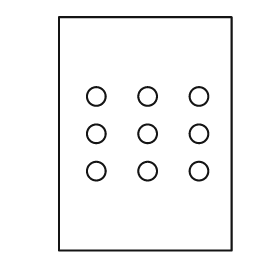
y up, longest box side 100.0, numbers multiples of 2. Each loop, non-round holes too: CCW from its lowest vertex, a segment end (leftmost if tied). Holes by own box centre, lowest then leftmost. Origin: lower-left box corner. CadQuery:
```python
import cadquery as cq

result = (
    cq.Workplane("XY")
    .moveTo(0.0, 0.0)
    .lineTo(74.0, 0.0)
    .lineTo(74.0, 100.0)
    .lineTo(0.0, 100.0)
    .close()
    .moveTo(16.0, 34.0)
    .circle(4.0)
    .moveTo(38.0, 34.0)
    .circle(4.0)
    .moveTo(60.0, 34.0)
    .circle(4.0)
    .moveTo(16.0, 50.0)
    .circle(4.0)
    .moveTo(38.0, 50.0)
    .circle(4.0)
    .moveTo(60.0, 50.0)
    .circle(4.0)
    .moveTo(16.0, 66.0)
    .circle(4.0)
    .moveTo(38.0, 66.0)
    .circle(4.0)
    .moveTo(60.0, 66.0)
    .circle(4.0)
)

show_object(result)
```